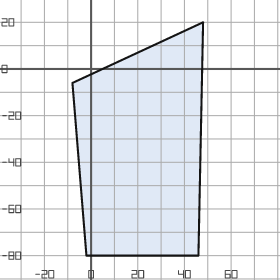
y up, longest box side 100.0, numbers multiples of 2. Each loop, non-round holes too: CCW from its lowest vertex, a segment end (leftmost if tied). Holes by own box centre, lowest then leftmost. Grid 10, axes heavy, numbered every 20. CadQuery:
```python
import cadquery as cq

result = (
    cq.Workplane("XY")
    .moveTo(-2.0, -80.0)
    .lineTo(46.0, -80.0)
    .lineTo(48.0, 20.0)
    .lineTo(-8.0, -6.0)
    .close()
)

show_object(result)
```